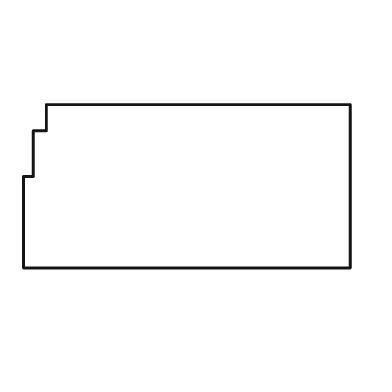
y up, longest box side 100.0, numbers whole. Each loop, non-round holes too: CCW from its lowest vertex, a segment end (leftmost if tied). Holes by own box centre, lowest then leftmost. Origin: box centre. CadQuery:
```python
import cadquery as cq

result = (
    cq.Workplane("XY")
    .moveTo(-50.0, -25.0)
    .lineTo(50.0, -25.0)
    .lineTo(50.0, 25.0)
    .lineTo(-43.0, 25.0)
    .lineTo(-43.0, 17.0)
    .lineTo(-47.0, 17.0)
    .lineTo(-47.0, 3.0)
    .lineTo(-50.0, 3.0)
    .close()
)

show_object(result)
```